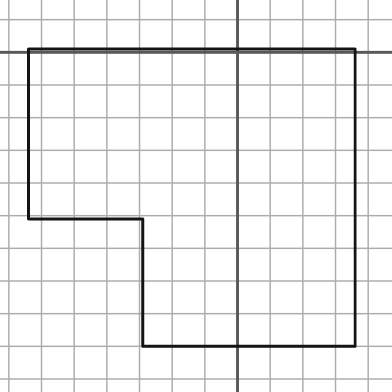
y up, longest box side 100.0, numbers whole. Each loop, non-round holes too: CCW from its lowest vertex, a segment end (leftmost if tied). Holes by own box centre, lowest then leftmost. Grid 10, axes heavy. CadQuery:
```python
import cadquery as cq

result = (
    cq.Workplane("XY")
    .moveTo(-29.0, -90.0)
    .lineTo(36.0, -90.0)
    .lineTo(36.0, 1.0)
    .lineTo(-64.0, 1.0)
    .lineTo(-64.0, -51.0)
    .lineTo(-29.0, -51.0)
    .close()
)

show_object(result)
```